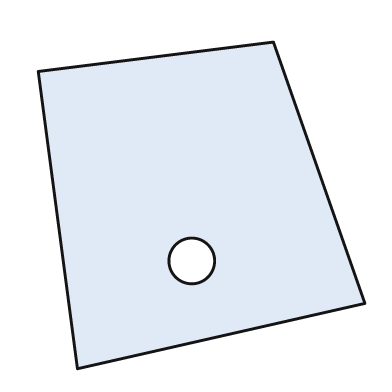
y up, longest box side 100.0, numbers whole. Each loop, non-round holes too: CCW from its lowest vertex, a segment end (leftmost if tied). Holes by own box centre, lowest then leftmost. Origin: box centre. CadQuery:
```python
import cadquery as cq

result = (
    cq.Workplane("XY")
    .moveTo(-38.0, -50.0)
    .lineTo(50.0, -30.0)
    .lineTo(22.0, 50.0)
    .lineTo(-50.0, 41.0)
    .close()
    .moveTo(-3.0, -17.0)
    .circle(7.0)
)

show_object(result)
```